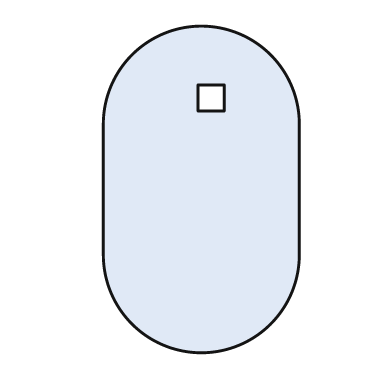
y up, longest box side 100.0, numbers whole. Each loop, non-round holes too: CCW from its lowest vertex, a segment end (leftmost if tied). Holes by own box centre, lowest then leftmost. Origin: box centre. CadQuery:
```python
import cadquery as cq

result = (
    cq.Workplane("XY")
    .moveTo(-30.0, -20.0)
    .threePointArc((0.0, -50.0), (30.0, -20.0))
    .lineTo(30.0, 20.0)
    .threePointArc((0.0, 50.0), (-30.0, 20.0))
    .close()
    .moveTo(-1.0, 24.0)
    .lineTo(7.0, 24.0)
    .lineTo(7.0, 32.0)
    .lineTo(-1.0, 32.0)
    .close()
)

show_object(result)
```